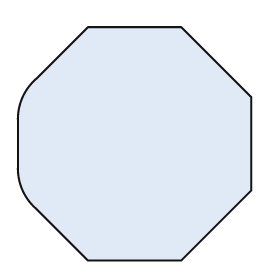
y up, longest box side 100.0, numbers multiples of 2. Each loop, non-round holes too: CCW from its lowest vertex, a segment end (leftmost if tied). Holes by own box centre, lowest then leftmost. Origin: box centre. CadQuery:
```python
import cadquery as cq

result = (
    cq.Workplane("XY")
    .moveTo(-20.0, -50.0)
    .lineTo(20.0, -50.0)
    .lineTo(50.0, -20.0)
    .lineTo(50.0, 20.0)
    .lineTo(20.0, 50.0)
    .lineTo(-20.0, 50.0)
    .lineTo(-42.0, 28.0)
    .threePointArc((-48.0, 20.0), (-50.0, 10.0))
    .lineTo(-50.0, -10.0)
    .threePointArc((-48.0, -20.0), (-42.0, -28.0))
    .close()
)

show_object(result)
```